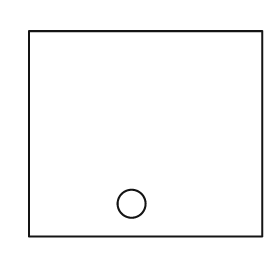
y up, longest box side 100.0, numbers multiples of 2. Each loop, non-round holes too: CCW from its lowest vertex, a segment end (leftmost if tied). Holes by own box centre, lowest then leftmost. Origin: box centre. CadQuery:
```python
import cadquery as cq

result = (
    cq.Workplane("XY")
    .moveTo(-50.0, -44.0)
    .lineTo(50.0, -44.0)
    .lineTo(50.0, 44.0)
    .lineTo(-50.0, 44.0)
    .close()
    .moveTo(-6.0, -30.0)
    .circle(6.0)
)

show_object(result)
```